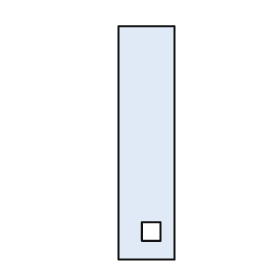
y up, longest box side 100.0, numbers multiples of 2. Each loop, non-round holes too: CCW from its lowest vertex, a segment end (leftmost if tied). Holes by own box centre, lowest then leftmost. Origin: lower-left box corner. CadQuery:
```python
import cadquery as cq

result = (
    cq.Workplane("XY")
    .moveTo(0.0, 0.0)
    .lineTo(24.0, 0.0)
    .lineTo(24.0, 100.0)
    .lineTo(0.0, 100.0)
    .close()
    .moveTo(10.0, 8.0)
    .lineTo(18.0, 8.0)
    .lineTo(18.0, 16.0)
    .lineTo(10.0, 16.0)
    .close()
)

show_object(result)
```